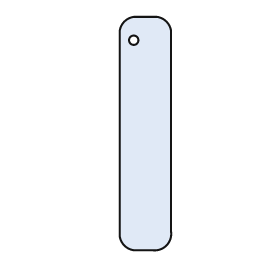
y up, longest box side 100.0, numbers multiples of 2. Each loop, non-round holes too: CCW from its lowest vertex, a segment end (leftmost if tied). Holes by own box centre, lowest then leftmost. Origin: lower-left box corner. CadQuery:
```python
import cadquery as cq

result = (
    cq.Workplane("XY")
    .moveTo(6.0, 0.0)
    .lineTo(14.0, 0.0)
    .threePointArc((20.0, 2.0), (22.0, 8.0))
    .lineTo(22.0, 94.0)
    .threePointArc((20.0, 98.0), (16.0, 100.0))
    .lineTo(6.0, 100.0)
    .threePointArc((2.0, 98.0), (0.0, 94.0))
    .lineTo(0.0, 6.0)
    .threePointArc((2.0, 2.0), (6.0, 0.0))
    .close()
    .moveTo(6.0, 90.0)
    .circle(2.0)
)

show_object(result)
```